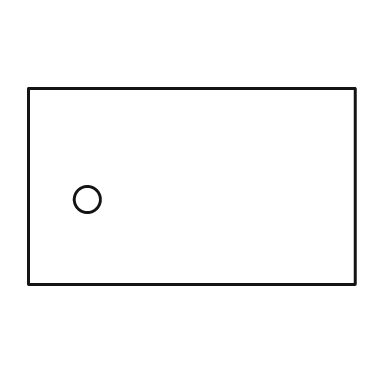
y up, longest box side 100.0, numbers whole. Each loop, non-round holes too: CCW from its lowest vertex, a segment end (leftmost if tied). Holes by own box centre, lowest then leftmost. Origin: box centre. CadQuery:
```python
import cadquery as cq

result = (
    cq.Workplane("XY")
    .moveTo(-50.0, -30.0)
    .lineTo(50.0, -30.0)
    .lineTo(50.0, 30.0)
    .lineTo(-50.0, 30.0)
    .close()
    .moveTo(-32.0, -4.0)
    .circle(4.0)
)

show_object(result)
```